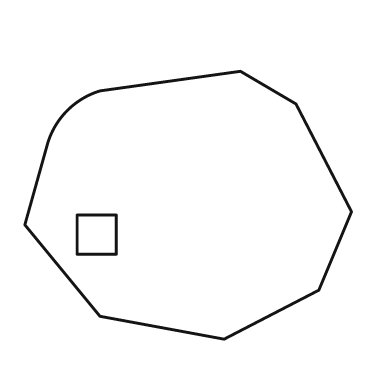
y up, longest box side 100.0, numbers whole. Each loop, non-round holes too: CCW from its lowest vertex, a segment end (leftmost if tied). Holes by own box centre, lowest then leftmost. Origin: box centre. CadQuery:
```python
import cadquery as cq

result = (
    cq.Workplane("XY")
    .moveTo(11.0, -41.0)
    .lineTo(40.0, -26.0)
    .lineTo(50.0, -2.0)
    .lineTo(33.0, 31.0)
    .lineTo(16.0, 41.0)
    .lineTo(-27.0, 35.0)
    .threePointArc((-37.0, 29.0), (-43.0, 19.0))
    .lineTo(-50.0, -6.0)
    .lineTo(-27.0, -34.0)
    .close()
    .moveTo(-34.0, -15.0)
    .lineTo(-22.0, -15.0)
    .lineTo(-22.0, -3.0)
    .lineTo(-34.0, -3.0)
    .close()
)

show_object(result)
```